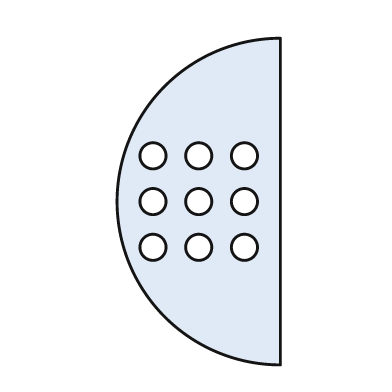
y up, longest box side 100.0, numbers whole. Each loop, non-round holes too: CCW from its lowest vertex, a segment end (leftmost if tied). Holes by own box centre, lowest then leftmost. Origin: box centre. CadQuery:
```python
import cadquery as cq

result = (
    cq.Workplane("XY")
    .moveTo(25.0, -50.0)
    .lineTo(25.0, 50.0)
    .threePointArc((-25.0, 0.0), (25.0, -50.0))
    .close()
    .moveTo(-14.0, -14.0)
    .circle(4.0)
    .moveTo(0.0, -14.0)
    .circle(4.0)
    .moveTo(14.0, -14.0)
    .circle(4.0)
    .moveTo(-14.0, 0.0)
    .circle(4.0)
    .moveTo(0.0, 0.0)
    .circle(4.0)
    .moveTo(14.0, 0.0)
    .circle(4.0)
    .moveTo(-14.0, 14.0)
    .circle(4.0)
    .moveTo(0.0, 14.0)
    .circle(4.0)
    .moveTo(14.0, 14.0)
    .circle(4.0)
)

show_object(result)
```